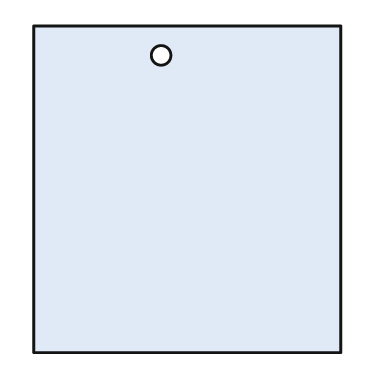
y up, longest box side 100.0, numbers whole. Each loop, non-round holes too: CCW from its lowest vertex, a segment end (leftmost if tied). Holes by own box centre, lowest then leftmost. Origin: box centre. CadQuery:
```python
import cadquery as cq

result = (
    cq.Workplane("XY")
    .moveTo(-47.0, -50.0)
    .lineTo(47.0, -50.0)
    .lineTo(47.0, 50.0)
    .lineTo(-47.0, 50.0)
    .close()
    .moveTo(-8.0, 41.0)
    .circle(3.0)
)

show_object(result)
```